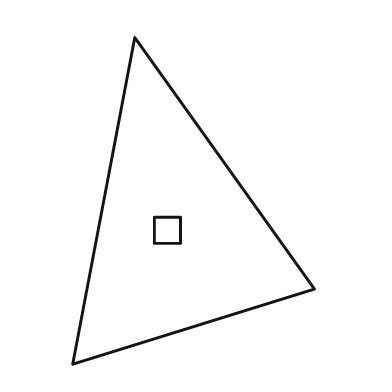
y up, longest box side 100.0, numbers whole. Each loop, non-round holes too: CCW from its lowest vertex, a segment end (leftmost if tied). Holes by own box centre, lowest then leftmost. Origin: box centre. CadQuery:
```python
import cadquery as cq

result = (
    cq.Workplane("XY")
    .moveTo(-37.0, -50.0)
    .lineTo(37.0, -27.0)
    .lineTo(-18.0, 50.0)
    .close()
    .moveTo(-12.0, -13.0)
    .lineTo(-4.0, -13.0)
    .lineTo(-4.0, -5.0)
    .lineTo(-12.0, -5.0)
    .close()
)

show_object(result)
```